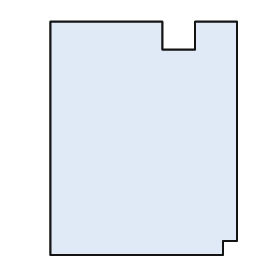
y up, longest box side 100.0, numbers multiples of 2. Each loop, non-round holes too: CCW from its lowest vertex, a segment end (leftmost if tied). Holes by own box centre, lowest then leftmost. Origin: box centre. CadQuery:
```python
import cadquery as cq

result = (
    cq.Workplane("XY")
    .moveTo(-40.0, -50.0)
    .lineTo(34.0, -50.0)
    .lineTo(34.0, -44.0)
    .lineTo(40.0, -44.0)
    .lineTo(40.0, 50.0)
    .lineTo(22.0, 50.0)
    .lineTo(22.0, 38.0)
    .lineTo(8.0, 38.0)
    .lineTo(8.0, 50.0)
    .lineTo(-40.0, 50.0)
    .close()
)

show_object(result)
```